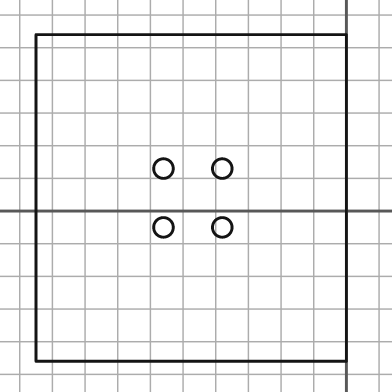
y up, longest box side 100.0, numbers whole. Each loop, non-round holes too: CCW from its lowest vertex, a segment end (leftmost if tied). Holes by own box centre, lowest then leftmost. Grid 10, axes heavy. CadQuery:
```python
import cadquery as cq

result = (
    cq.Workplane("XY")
    .moveTo(-95.0, -46.0)
    .lineTo(0.0, -46.0)
    .lineTo(0.0, 54.0)
    .lineTo(-95.0, 54.0)
    .close()
    .moveTo(-56.0, -5.0)
    .circle(3.0)
    .moveTo(-38.0, -5.0)
    .circle(3.0)
    .moveTo(-56.0, 13.0)
    .circle(3.0)
    .moveTo(-38.0, 13.0)
    .circle(3.0)
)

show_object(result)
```